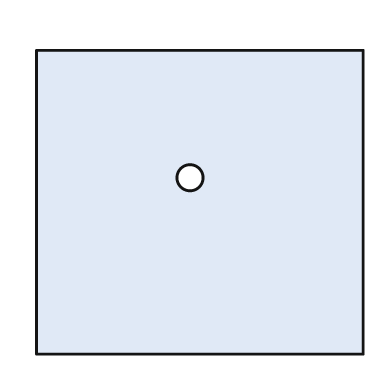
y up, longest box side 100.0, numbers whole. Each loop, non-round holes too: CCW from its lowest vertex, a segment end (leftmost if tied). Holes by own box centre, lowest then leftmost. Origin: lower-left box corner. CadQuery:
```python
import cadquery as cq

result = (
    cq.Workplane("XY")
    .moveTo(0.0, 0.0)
    .lineTo(100.0, 0.0)
    .lineTo(100.0, 93.0)
    .lineTo(0.0, 93.0)
    .close()
    .moveTo(47.0, 54.0)
    .circle(4.0)
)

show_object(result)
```